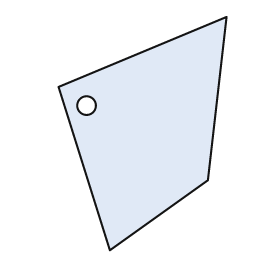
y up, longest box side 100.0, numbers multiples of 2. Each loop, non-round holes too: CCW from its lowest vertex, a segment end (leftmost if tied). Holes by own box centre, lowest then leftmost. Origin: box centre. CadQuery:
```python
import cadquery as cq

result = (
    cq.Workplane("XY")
    .moveTo(-14.0, -50.0)
    .lineTo(28.0, -20.0)
    .lineTo(36.0, 50.0)
    .lineTo(-36.0, 20.0)
    .close()
    .moveTo(-24.0, 12.0)
    .circle(4.0)
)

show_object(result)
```